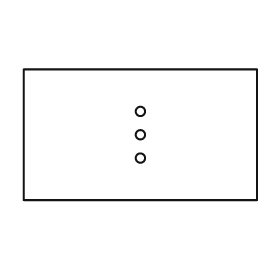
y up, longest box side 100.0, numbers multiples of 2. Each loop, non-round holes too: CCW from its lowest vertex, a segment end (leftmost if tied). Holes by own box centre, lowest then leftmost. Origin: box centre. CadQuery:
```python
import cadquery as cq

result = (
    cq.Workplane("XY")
    .moveTo(-50.0, -28.0)
    .lineTo(50.0, -28.0)
    .lineTo(50.0, 28.0)
    .lineTo(-50.0, 28.0)
    .close()
    .moveTo(0.0, -10.0)
    .circle(2.0)
    .moveTo(0.0, 0.0)
    .circle(2.0)
    .moveTo(0.0, 10.0)
    .circle(2.0)
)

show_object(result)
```